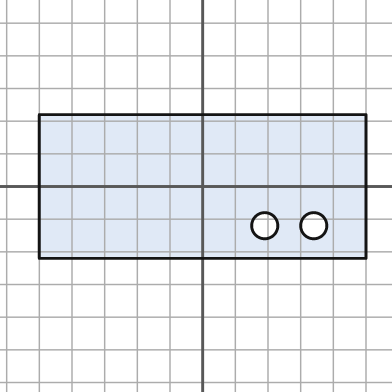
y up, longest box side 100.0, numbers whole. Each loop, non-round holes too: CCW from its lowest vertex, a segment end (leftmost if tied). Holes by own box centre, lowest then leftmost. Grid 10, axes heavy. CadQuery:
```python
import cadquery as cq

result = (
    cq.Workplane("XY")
    .moveTo(-50.0, -22.0)
    .lineTo(50.0, -22.0)
    .lineTo(50.0, 22.0)
    .lineTo(-50.0, 22.0)
    .close()
    .moveTo(19.0, -12.0)
    .circle(4.0)
    .moveTo(34.0, -12.0)
    .circle(4.0)
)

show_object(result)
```